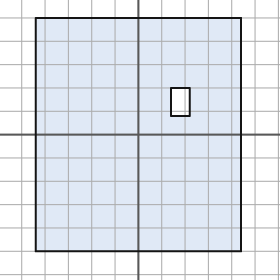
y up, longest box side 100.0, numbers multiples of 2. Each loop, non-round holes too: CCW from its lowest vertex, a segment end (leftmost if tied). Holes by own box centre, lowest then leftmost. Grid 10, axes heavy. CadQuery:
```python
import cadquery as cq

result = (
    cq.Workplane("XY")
    .moveTo(-44.0, -50.0)
    .lineTo(44.0, -50.0)
    .lineTo(44.0, 50.0)
    .lineTo(-44.0, 50.0)
    .close()
    .moveTo(14.0, 8.0)
    .lineTo(22.0, 8.0)
    .lineTo(22.0, 20.0)
    .lineTo(14.0, 20.0)
    .close()
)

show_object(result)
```